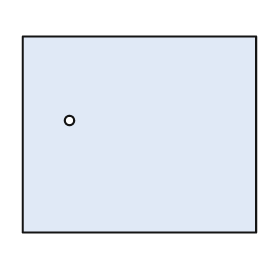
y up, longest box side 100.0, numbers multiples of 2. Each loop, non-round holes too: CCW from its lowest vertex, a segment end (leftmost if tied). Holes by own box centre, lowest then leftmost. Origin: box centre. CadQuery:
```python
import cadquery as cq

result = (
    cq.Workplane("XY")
    .moveTo(-50.0, -42.0)
    .lineTo(50.0, -42.0)
    .lineTo(50.0, 42.0)
    .lineTo(-50.0, 42.0)
    .close()
    .moveTo(-30.0, 6.0)
    .circle(2.0)
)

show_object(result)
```